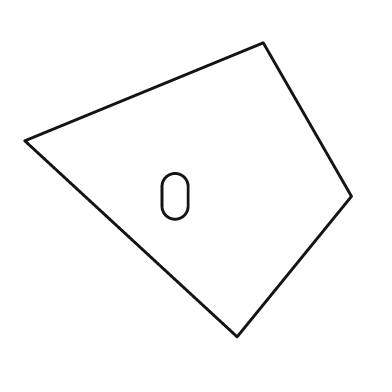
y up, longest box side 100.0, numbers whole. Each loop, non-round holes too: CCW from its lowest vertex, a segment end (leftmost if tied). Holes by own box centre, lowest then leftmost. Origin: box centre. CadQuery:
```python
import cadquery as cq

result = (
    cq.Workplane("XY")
    .moveTo(15.0, -45.0)
    .lineTo(50.0, -2.0)
    .lineTo(23.0, 45.0)
    .lineTo(-50.0, 15.0)
    .close()
    .moveTo(-8.0, -5.0)
    .threePointArc((-4.0, -9.0), (0.0, -5.0))
    .lineTo(0.0, 1.0)
    .threePointArc((-4.0, 5.0), (-8.0, 1.0))
    .close()
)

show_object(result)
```